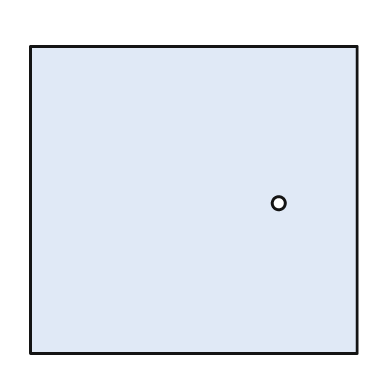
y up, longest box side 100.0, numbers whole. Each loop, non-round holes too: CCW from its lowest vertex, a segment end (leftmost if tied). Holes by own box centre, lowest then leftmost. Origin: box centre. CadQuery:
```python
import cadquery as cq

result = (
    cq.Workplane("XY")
    .moveTo(-50.0, -47.0)
    .lineTo(50.0, -47.0)
    .lineTo(50.0, 47.0)
    .lineTo(-50.0, 47.0)
    .close()
    .moveTo(26.0, -1.0)
    .circle(2.0)
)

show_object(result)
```